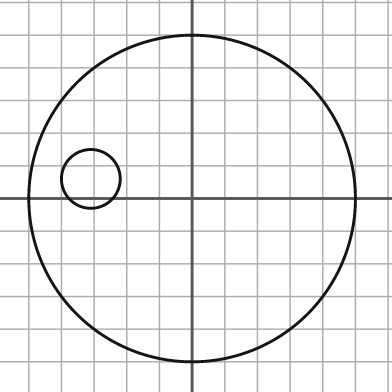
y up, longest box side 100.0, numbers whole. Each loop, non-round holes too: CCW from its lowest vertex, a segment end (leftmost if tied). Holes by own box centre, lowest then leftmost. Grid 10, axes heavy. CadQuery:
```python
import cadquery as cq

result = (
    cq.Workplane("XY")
    .moveTo(0.0, 0.0)
    .circle(50.0)
    .moveTo(-31.0, 6.0)
    .circle(9.0)
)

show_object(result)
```